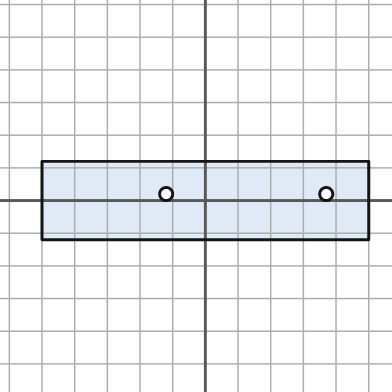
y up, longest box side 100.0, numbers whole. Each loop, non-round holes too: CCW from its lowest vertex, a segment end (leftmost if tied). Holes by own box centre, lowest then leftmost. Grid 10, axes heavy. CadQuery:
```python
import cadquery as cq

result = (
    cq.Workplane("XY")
    .moveTo(-50.0, -12.0)
    .lineTo(50.0, -12.0)
    .lineTo(50.0, 12.0)
    .lineTo(-50.0, 12.0)
    .close()
    .moveTo(-12.0, 2.0)
    .circle(2.0)
    .moveTo(37.0, 2.0)
    .circle(2.0)
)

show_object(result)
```